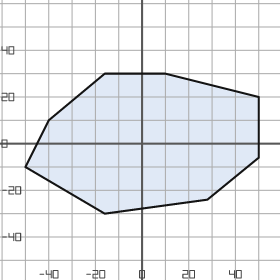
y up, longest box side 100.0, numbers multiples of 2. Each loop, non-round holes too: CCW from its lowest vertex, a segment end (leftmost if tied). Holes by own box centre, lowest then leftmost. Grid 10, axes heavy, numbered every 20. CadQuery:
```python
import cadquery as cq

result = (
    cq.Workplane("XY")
    .moveTo(-16.0, -30.0)
    .lineTo(28.0, -24.0)
    .lineTo(50.0, -6.0)
    .lineTo(50.0, 20.0)
    .lineTo(10.0, 30.0)
    .lineTo(-16.0, 30.0)
    .lineTo(-40.0, 10.0)
    .lineTo(-50.0, -10.0)
    .close()
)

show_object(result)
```